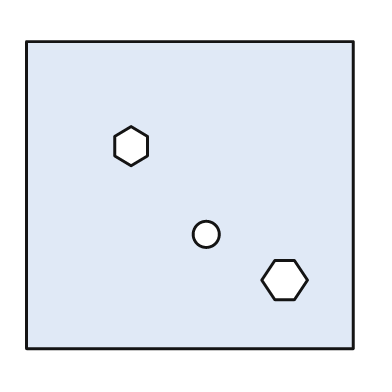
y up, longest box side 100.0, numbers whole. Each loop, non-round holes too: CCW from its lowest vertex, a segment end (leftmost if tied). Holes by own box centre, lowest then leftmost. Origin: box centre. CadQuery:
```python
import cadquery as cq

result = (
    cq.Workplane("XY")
    .moveTo(-50.0, -47.0)
    .lineTo(50.0, -47.0)
    .lineTo(50.0, 47.0)
    .lineTo(-50.0, 47.0)
    .close()
    .moveTo(26.0, -32.0)
    .lineTo(32.0, -32.0)
    .lineTo(36.0, -26.0)
    .lineTo(32.0, -20.0)
    .lineTo(26.0, -20.0)
    .lineTo(22.0, -26.0)
    .close()
    .moveTo(5.0, -12.0)
    .circle(4.0)
    .moveTo(-18.0, 9.0)
    .lineTo(-13.0, 12.0)
    .lineTo(-13.0, 18.0)
    .lineTo(-18.0, 21.0)
    .lineTo(-23.0, 18.0)
    .lineTo(-23.0, 12.0)
    .close()
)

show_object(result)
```